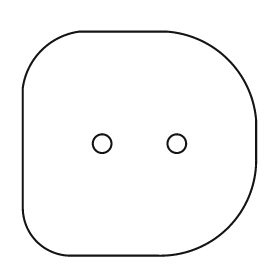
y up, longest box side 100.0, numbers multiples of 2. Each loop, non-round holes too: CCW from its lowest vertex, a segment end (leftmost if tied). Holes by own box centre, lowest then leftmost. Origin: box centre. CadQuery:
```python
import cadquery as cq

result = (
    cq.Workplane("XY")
    .moveTo(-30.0, -48.0)
    .lineTo(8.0, -48.0)
    .threePointArc((38.0, -36.0), (50.0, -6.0))
    .lineTo(50.0, 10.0)
    .threePointArc((38.0, 36.0), (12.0, 48.0))
    .lineTo(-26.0, 48.0)
    .threePointArc((-42.0, 40.0), (-50.0, 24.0))
    .lineTo(-50.0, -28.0)
    .threePointArc((-44.0, -42.0), (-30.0, -48.0))
    .close()
    .moveTo(-16.0, 0.0)
    .circle(4.0)
    .moveTo(16.0, 0.0)
    .circle(4.0)
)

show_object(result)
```